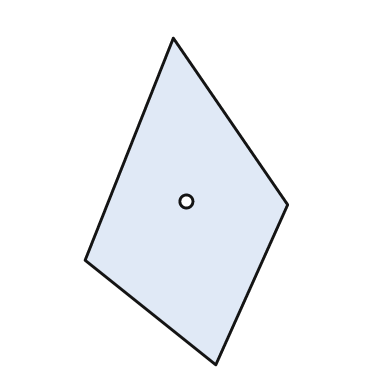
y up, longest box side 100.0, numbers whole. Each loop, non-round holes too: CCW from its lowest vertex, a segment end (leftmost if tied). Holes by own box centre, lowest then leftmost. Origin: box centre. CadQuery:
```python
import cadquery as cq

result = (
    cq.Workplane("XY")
    .moveTo(9.0, -50.0)
    .lineTo(31.0, -1.0)
    .lineTo(-4.0, 50.0)
    .lineTo(-31.0, -18.0)
    .close()
    .moveTo(0.0, 0.0)
    .circle(2.0)
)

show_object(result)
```